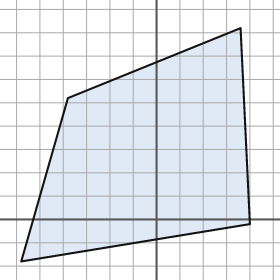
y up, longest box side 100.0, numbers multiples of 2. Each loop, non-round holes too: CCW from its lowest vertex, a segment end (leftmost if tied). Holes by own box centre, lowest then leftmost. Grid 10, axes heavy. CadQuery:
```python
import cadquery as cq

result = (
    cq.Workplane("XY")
    .moveTo(-58.0, -18.0)
    .lineTo(40.0, -2.0)
    .lineTo(36.0, 82.0)
    .lineTo(-38.0, 52.0)
    .close()
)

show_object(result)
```